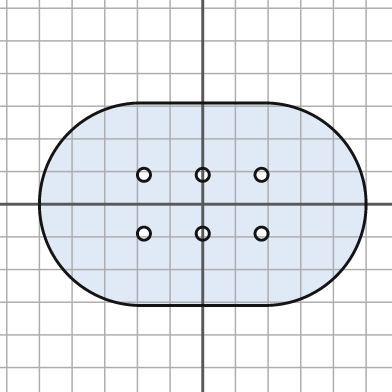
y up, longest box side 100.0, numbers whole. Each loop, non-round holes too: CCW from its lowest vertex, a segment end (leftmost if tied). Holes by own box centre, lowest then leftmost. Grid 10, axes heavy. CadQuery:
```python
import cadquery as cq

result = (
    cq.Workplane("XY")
    .moveTo(-19.0, -31.0)
    .lineTo(19.0, -31.0)
    .threePointArc((50.0, 0.0), (19.0, 31.0))
    .lineTo(-19.0, 31.0)
    .threePointArc((-50.0, 0.0), (-19.0, -31.0))
    .close()
    .moveTo(-18.0, -9.0)
    .circle(2.0)
    .moveTo(0.0, -9.0)
    .circle(2.0)
    .moveTo(18.0, -9.0)
    .circle(2.0)
    .moveTo(-18.0, 9.0)
    .circle(2.0)
    .moveTo(0.0, 9.0)
    .circle(2.0)
    .moveTo(18.0, 9.0)
    .circle(2.0)
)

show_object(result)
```